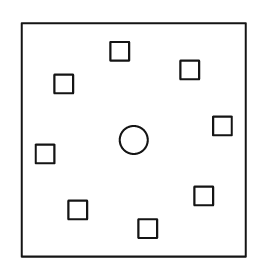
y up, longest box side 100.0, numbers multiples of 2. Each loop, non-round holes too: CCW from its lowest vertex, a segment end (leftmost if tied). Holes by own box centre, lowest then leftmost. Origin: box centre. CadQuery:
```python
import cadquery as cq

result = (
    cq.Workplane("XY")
    .moveTo(-48.0, -50.0)
    .lineTo(48.0, -50.0)
    .lineTo(48.0, 50.0)
    .lineTo(-48.0, 50.0)
    .close()
    .moveTo(2.0, -42.0)
    .lineTo(10.0, -42.0)
    .lineTo(10.0, -34.0)
    .lineTo(2.0, -34.0)
    .close()
    .moveTo(-28.0, -34.0)
    .lineTo(-20.0, -34.0)
    .lineTo(-20.0, -26.0)
    .lineTo(-28.0, -26.0)
    .close()
    .moveTo(26.0, -28.0)
    .lineTo(34.0, -28.0)
    .lineTo(34.0, -20.0)
    .lineTo(26.0, -20.0)
    .close()
    .moveTo(-42.0, -10.0)
    .lineTo(-34.0, -10.0)
    .lineTo(-34.0, -2.0)
    .lineTo(-42.0, -2.0)
    .close()
    .moveTo(0.0, 0.0)
    .circle(6.0)
    .moveTo(34.0, 2.0)
    .lineTo(42.0, 2.0)
    .lineTo(42.0, 10.0)
    .lineTo(34.0, 10.0)
    .close()
    .moveTo(-34.0, 20.0)
    .lineTo(-26.0, 20.0)
    .lineTo(-26.0, 28.0)
    .lineTo(-34.0, 28.0)
    .close()
    .moveTo(20.0, 26.0)
    .lineTo(28.0, 26.0)
    .lineTo(28.0, 34.0)
    .lineTo(20.0, 34.0)
    .close()
    .moveTo(-10.0, 34.0)
    .lineTo(-2.0, 34.0)
    .lineTo(-2.0, 42.0)
    .lineTo(-10.0, 42.0)
    .close()
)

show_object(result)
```